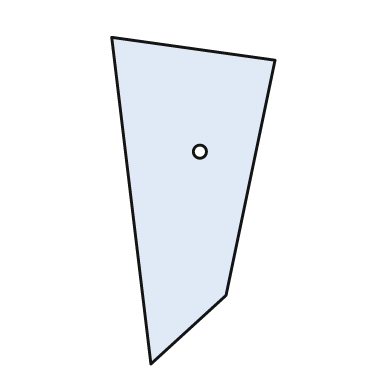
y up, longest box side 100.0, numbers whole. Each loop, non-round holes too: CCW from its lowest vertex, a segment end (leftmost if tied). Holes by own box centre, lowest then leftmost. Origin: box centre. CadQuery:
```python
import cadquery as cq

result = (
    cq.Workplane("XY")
    .moveTo(-13.0, -50.0)
    .lineTo(10.0, -29.0)
    .lineTo(25.0, 43.0)
    .lineTo(-25.0, 50.0)
    .close()
    .moveTo(2.0, 15.0)
    .circle(2.0)
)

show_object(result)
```